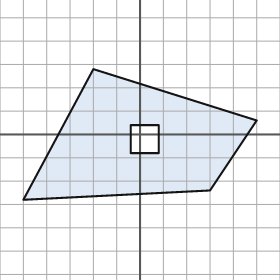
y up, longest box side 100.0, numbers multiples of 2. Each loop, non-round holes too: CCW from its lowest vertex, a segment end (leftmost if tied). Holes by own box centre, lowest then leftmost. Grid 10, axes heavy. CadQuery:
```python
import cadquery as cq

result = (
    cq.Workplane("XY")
    .moveTo(-50.0, -28.0)
    .lineTo(30.0, -24.0)
    .lineTo(50.0, 6.0)
    .lineTo(-20.0, 28.0)
    .close()
    .moveTo(-4.0, -8.0)
    .lineTo(8.0, -8.0)
    .lineTo(8.0, 4.0)
    .lineTo(-4.0, 4.0)
    .close()
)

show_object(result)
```